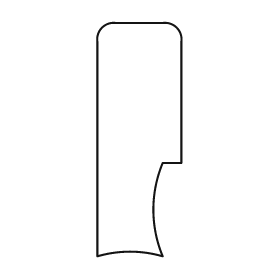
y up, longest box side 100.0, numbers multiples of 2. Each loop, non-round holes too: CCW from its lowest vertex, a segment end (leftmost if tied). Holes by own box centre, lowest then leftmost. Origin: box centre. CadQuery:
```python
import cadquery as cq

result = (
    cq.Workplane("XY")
    .moveTo(-18.0, -50.0)
    .threePointArc((-4.0, -48.0), (10.0, -50.0))
    .threePointArc((6.0, -30.0), (10.0, -10.0))
    .lineTo(18.0, -10.0)
    .lineTo(18.0, 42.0)
    .threePointArc((16.0, 48.0), (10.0, 50.0))
    .lineTo(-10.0, 50.0)
    .threePointArc((-16.0, 48.0), (-18.0, 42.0))
    .close()
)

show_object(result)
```